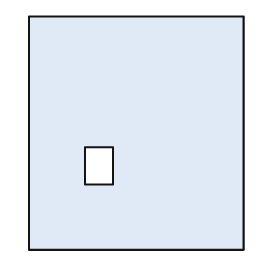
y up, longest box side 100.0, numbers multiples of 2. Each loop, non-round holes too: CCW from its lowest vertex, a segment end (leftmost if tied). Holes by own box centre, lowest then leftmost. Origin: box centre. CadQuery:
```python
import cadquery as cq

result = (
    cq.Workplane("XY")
    .moveTo(-46.0, -50.0)
    .lineTo(46.0, -50.0)
    .lineTo(46.0, 50.0)
    .lineTo(-46.0, 50.0)
    .close()
    .moveTo(-22.0, -22.0)
    .lineTo(-10.0, -22.0)
    .lineTo(-10.0, -6.0)
    .lineTo(-22.0, -6.0)
    .close()
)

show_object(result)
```